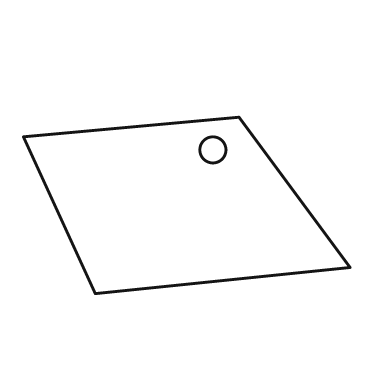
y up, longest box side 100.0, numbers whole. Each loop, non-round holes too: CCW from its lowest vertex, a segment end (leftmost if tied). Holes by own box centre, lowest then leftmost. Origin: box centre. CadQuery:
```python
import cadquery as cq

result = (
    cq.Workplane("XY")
    .moveTo(-28.0, -27.0)
    .lineTo(50.0, -19.0)
    .lineTo(16.0, 27.0)
    .lineTo(-50.0, 21.0)
    .close()
    .moveTo(8.0, 17.0)
    .circle(4.0)
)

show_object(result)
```